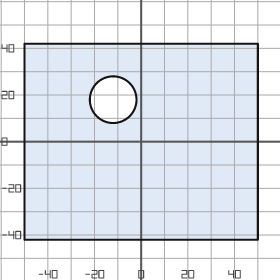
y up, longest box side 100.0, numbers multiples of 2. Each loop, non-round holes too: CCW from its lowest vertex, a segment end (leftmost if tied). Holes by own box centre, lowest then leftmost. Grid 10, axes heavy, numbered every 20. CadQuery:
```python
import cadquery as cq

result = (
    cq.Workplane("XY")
    .moveTo(-50.0, -42.0)
    .lineTo(50.0, -42.0)
    .lineTo(50.0, 42.0)
    .lineTo(-50.0, 42.0)
    .close()
    .moveTo(-12.0, 18.0)
    .circle(10.0)
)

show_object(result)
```